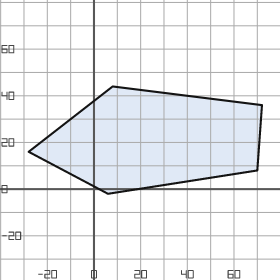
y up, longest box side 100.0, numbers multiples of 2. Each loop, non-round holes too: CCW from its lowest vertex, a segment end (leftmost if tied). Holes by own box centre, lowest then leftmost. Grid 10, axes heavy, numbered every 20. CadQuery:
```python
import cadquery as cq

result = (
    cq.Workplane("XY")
    .moveTo(6.0, -2.0)
    .lineTo(70.0, 8.0)
    .lineTo(72.0, 36.0)
    .lineTo(8.0, 44.0)
    .lineTo(-28.0, 16.0)
    .close()
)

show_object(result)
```